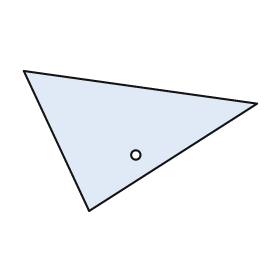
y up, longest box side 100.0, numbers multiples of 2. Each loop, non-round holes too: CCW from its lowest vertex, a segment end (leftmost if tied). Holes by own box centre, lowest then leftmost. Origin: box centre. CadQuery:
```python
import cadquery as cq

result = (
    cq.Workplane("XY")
    .moveTo(-22.0, -30.0)
    .lineTo(50.0, 16.0)
    .lineTo(-50.0, 30.0)
    .close()
    .moveTo(-2.0, -6.0)
    .circle(2.0)
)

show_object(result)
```